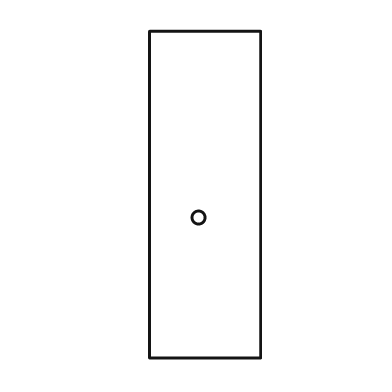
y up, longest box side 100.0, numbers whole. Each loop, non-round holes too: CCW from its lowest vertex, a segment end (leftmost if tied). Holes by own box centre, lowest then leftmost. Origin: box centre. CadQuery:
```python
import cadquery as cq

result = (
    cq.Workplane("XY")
    .moveTo(-17.0, -50.0)
    .lineTo(17.0, -50.0)
    .lineTo(17.0, 50.0)
    .lineTo(-17.0, 50.0)
    .close()
    .moveTo(-2.0, -7.0)
    .circle(2.0)
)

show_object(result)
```